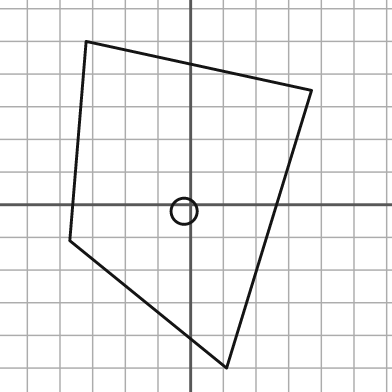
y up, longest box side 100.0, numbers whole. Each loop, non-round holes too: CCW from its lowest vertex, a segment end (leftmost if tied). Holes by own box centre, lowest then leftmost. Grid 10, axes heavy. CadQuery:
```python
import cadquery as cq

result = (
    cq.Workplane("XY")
    .moveTo(11.0, -50.0)
    .lineTo(37.0, 35.0)
    .lineTo(-32.0, 50.0)
    .lineTo(-37.0, -11.0)
    .close()
    .moveTo(-2.0, -2.0)
    .circle(4.0)
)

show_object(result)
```